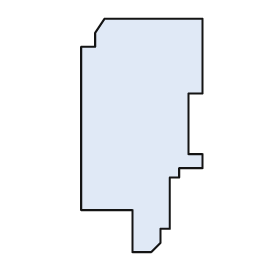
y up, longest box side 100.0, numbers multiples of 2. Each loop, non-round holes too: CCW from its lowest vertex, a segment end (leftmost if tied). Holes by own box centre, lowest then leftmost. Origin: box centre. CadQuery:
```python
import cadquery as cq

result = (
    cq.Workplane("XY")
    .moveTo(-4.0, -50.0)
    .lineTo(4.0, -50.0)
    .lineTo(8.0, -46.0)
    .lineTo(8.0, -40.0)
    .lineTo(12.0, -40.0)
    .lineTo(12.0, -18.0)
    .lineTo(16.0, -18.0)
    .lineTo(16.0, -14.0)
    .lineTo(26.0, -14.0)
    .lineTo(26.0, -8.0)
    .lineTo(20.0, -8.0)
    .lineTo(20.0, 18.0)
    .lineTo(26.0, 18.0)
    .lineTo(26.0, 50.0)
    .lineTo(-16.0, 50.0)
    .lineTo(-20.0, 44.0)
    .lineTo(-20.0, 38.0)
    .lineTo(-26.0, 38.0)
    .lineTo(-26.0, -32.0)
    .lineTo(-4.0, -32.0)
    .close()
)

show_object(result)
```